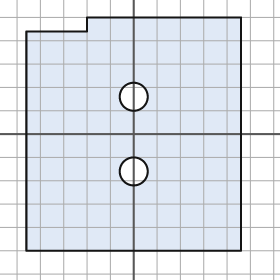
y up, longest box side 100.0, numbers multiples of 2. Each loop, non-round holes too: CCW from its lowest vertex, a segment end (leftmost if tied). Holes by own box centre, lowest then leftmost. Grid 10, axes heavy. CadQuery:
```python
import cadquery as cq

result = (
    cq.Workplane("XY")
    .moveTo(-46.0, -50.0)
    .lineTo(46.0, -50.0)
    .lineTo(46.0, 50.0)
    .lineTo(-20.0, 50.0)
    .lineTo(-20.0, 44.0)
    .lineTo(-46.0, 44.0)
    .close()
    .moveTo(0.0, -16.0)
    .circle(6.0)
    .moveTo(0.0, 16.0)
    .circle(6.0)
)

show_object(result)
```